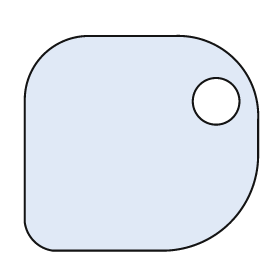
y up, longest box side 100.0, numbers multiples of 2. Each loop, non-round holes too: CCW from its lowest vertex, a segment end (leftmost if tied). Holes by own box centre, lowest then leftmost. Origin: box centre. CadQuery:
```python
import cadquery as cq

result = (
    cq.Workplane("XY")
    .moveTo(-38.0, -46.0)
    .lineTo(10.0, -46.0)
    .threePointArc((38.0, -34.0), (50.0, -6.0))
    .lineTo(50.0, 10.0)
    .threePointArc((40.0, 36.0), (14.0, 46.0))
    .lineTo(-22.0, 46.0)
    .threePointArc((-42.0, 38.0), (-50.0, 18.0))
    .lineTo(-50.0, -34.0)
    .threePointArc((-46.0, -42.0), (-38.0, -46.0))
    .close()
    .moveTo(32.0, 18.0)
    .circle(10.0)
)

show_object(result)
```